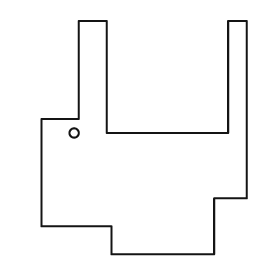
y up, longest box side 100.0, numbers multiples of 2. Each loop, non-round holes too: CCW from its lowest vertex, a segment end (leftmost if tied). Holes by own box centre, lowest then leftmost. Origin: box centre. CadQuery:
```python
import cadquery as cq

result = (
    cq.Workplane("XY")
    .moveTo(-14.0, -50.0)
    .lineTo(30.0, -50.0)
    .lineTo(30.0, -26.0)
    .lineTo(44.0, -26.0)
    .lineTo(44.0, 50.0)
    .lineTo(36.0, 50.0)
    .lineTo(36.0, 2.0)
    .lineTo(-16.0, 2.0)
    .lineTo(-16.0, 50.0)
    .lineTo(-28.0, 50.0)
    .lineTo(-28.0, 8.0)
    .lineTo(-44.0, 8.0)
    .lineTo(-44.0, -38.0)
    .lineTo(-14.0, -38.0)
    .close()
    .moveTo(-30.0, 2.0)
    .circle(2.0)
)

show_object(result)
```